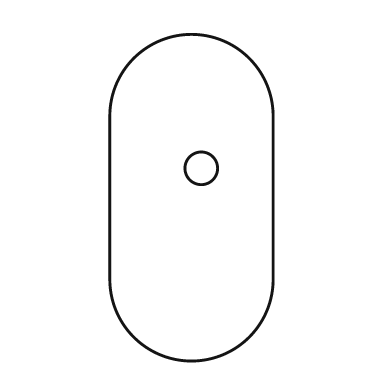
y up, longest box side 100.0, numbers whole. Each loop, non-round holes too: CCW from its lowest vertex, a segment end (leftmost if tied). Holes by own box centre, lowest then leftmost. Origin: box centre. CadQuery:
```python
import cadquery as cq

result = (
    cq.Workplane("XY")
    .moveTo(-25.0, -25.0)
    .threePointArc((0.0, -50.0), (25.0, -25.0))
    .lineTo(25.0, 25.0)
    .threePointArc((0.0, 50.0), (-25.0, 25.0))
    .close()
    .moveTo(3.0, 9.0)
    .circle(5.0)
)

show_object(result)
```